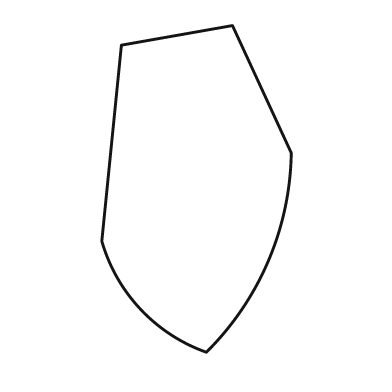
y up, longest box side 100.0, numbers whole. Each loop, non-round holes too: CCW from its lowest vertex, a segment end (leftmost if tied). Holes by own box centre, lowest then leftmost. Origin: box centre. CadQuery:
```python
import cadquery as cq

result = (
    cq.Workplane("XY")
    .moveTo(3.0, -50.0)
    .threePointArc((22.0, -22.0), (29.0, 11.0))
    .lineTo(11.0, 50.0)
    .lineTo(-23.0, 44.0)
    .lineTo(-29.0, -16.0)
    .threePointArc((-17.0, -37.0), (3.0, -50.0))
    .close()
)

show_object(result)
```